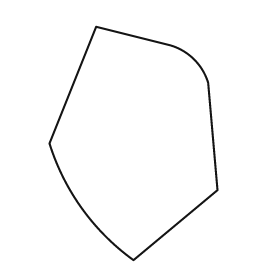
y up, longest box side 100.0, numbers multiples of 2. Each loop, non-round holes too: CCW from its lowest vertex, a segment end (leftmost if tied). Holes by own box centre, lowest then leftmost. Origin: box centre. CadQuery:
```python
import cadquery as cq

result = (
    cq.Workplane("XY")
    .moveTo(0.0, -50.0)
    .lineTo(36.0, -20.0)
    .lineTo(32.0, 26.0)
    .threePointArc((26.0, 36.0), (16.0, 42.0))
    .lineTo(-16.0, 50.0)
    .lineTo(-36.0, 0.0)
    .threePointArc((-22.0, -28.0), (0.0, -50.0))
    .close()
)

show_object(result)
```